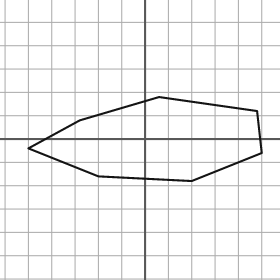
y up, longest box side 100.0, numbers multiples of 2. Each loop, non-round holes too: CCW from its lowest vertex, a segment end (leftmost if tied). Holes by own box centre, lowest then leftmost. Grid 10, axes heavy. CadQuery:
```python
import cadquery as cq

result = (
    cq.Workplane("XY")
    .moveTo(20.0, -18.0)
    .lineTo(50.0, -6.0)
    .lineTo(48.0, 12.0)
    .lineTo(6.0, 18.0)
    .lineTo(-28.0, 8.0)
    .lineTo(-50.0, -4.0)
    .lineTo(-20.0, -16.0)
    .close()
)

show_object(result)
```